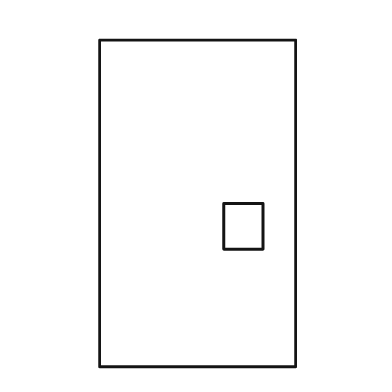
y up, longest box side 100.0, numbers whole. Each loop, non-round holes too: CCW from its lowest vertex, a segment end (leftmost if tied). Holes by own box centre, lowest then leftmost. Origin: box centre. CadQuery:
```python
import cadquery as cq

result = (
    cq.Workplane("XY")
    .moveTo(-30.0, -50.0)
    .lineTo(30.0, -50.0)
    .lineTo(30.0, 50.0)
    .lineTo(-30.0, 50.0)
    .close()
    .moveTo(8.0, -14.0)
    .lineTo(20.0, -14.0)
    .lineTo(20.0, 0.0)
    .lineTo(8.0, 0.0)
    .close()
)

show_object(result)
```